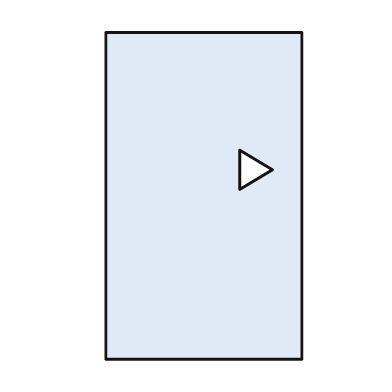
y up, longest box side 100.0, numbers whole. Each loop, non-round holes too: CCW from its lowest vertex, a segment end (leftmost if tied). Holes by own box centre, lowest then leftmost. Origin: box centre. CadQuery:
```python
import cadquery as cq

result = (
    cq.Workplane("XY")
    .moveTo(-30.0, -50.0)
    .lineTo(30.0, -50.0)
    .lineTo(30.0, 50.0)
    .lineTo(-30.0, 50.0)
    .close()
    .moveTo(11.0, 2.0)
    .lineTo(21.0, 8.0)
    .lineTo(11.0, 14.0)
    .close()
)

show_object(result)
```